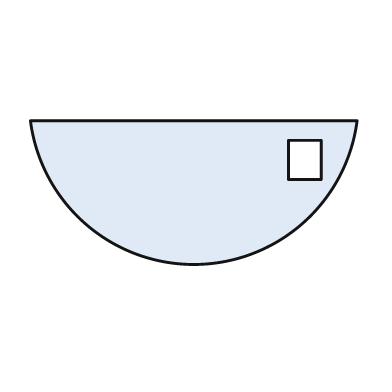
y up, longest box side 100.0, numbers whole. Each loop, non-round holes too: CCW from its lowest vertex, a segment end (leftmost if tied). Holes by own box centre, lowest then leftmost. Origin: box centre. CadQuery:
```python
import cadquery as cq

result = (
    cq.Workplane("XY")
    .moveTo(-50.0, 22.0)
    .threePointArc((0.0, -22.0), (50.0, 22.0))
    .close()
    .moveTo(29.0, 4.0)
    .lineTo(39.0, 4.0)
    .lineTo(39.0, 16.0)
    .lineTo(29.0, 16.0)
    .close()
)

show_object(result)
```